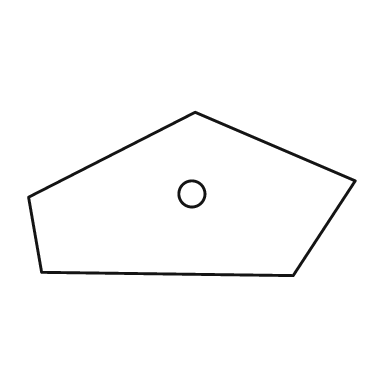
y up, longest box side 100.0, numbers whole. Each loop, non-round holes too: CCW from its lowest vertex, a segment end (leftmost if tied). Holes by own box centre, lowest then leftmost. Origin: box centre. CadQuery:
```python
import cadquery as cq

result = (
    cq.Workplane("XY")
    .moveTo(31.0, -25.0)
    .lineTo(50.0, 4.0)
    .lineTo(1.0, 25.0)
    .lineTo(-50.0, -1.0)
    .lineTo(-46.0, -24.0)
    .close()
    .moveTo(0.0, 0.0)
    .circle(4.0)
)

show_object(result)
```